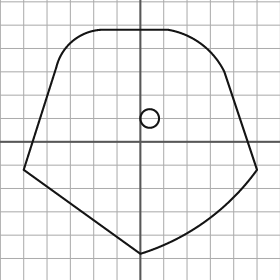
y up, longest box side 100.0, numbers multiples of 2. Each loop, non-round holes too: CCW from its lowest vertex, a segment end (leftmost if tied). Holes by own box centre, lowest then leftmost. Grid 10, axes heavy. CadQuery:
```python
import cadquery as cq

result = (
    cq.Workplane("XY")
    .moveTo(0.0, -48.0)
    .threePointArc((28.0, -34.0), (50.0, -12.0))
    .lineTo(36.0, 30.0)
    .threePointArc((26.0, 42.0), (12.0, 48.0))
    .lineTo(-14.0, 48.0)
    .threePointArc((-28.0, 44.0), (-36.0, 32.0))
    .lineTo(-50.0, -12.0)
    .close()
    .moveTo(4.0, 10.0)
    .circle(4.0)
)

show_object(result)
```